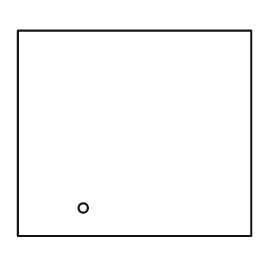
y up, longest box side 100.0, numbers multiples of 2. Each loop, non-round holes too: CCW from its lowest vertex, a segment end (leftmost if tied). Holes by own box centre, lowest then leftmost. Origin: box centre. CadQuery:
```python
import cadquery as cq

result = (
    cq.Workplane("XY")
    .moveTo(-50.0, -44.0)
    .lineTo(50.0, -44.0)
    .lineTo(50.0, 44.0)
    .lineTo(-50.0, 44.0)
    .close()
    .moveTo(-22.0, -32.0)
    .circle(2.0)
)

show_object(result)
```